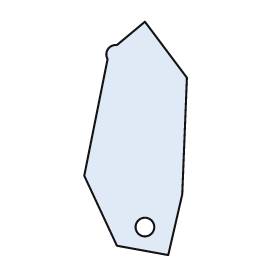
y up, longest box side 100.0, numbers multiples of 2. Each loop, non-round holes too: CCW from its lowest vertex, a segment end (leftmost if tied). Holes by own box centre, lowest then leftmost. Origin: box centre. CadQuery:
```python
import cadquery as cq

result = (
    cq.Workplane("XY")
    .moveTo(14.0, -50.0)
    .lineTo(20.0, -24.0)
    .lineTo(22.0, 26.0)
    .lineTo(4.0, 50.0)
    .lineTo(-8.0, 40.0)
    .threePointArc((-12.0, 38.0), (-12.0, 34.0))
    .lineTo(-22.0, -16.0)
    .lineTo(-8.0, -46.0)
    .close()
    .moveTo(4.0, -38.0)
    .circle(4.0)
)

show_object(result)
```